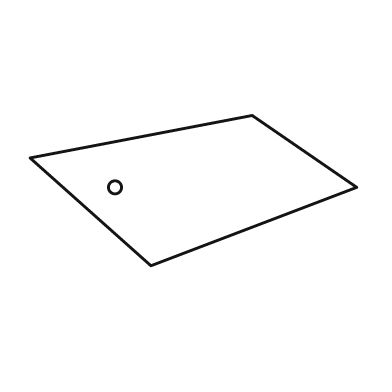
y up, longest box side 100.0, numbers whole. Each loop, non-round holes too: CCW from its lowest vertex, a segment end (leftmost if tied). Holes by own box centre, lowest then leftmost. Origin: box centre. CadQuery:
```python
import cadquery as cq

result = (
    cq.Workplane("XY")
    .moveTo(-13.0, -23.0)
    .lineTo(50.0, 1.0)
    .lineTo(18.0, 23.0)
    .lineTo(-50.0, 10.0)
    .close()
    .moveTo(-24.0, 1.0)
    .circle(2.0)
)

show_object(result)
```